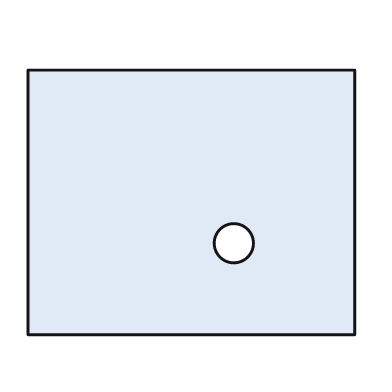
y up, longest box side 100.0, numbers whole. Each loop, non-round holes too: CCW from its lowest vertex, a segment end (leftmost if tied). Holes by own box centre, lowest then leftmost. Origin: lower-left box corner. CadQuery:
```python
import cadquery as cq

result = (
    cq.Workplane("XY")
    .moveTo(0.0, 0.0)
    .lineTo(100.0, 0.0)
    .lineTo(100.0, 81.0)
    .lineTo(0.0, 81.0)
    .close()
    .moveTo(63.0, 28.0)
    .circle(6.0)
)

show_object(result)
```